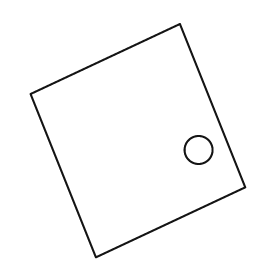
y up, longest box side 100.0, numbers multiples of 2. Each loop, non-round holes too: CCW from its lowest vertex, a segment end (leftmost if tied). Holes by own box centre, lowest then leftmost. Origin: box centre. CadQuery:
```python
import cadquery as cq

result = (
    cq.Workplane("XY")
    .moveTo(-18.0, -50.0)
    .lineTo(46.0, -20.0)
    .lineTo(18.0, 50.0)
    .lineTo(-46.0, 20.0)
    .close()
    .moveTo(26.0, -4.0)
    .circle(6.0)
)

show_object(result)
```